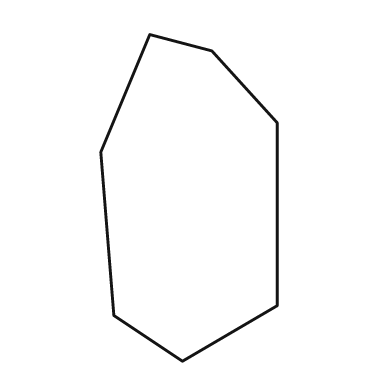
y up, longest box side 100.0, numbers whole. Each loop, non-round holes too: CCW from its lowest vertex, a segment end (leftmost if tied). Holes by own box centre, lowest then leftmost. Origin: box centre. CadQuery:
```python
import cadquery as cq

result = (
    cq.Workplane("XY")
    .moveTo(-2.0, -50.0)
    .lineTo(27.0, -33.0)
    .lineTo(27.0, 23.0)
    .lineTo(7.0, 45.0)
    .lineTo(-12.0, 50.0)
    .lineTo(-27.0, 14.0)
    .lineTo(-23.0, -36.0)
    .close()
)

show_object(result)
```